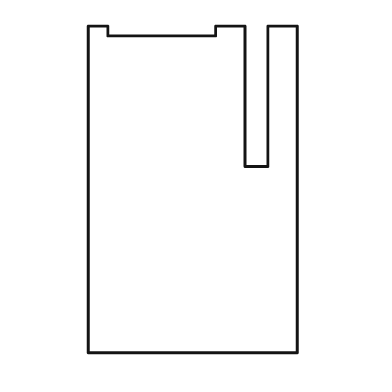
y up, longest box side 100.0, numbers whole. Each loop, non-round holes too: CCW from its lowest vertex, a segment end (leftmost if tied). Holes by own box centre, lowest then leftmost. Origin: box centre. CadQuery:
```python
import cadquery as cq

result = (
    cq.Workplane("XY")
    .moveTo(-32.0, -50.0)
    .lineTo(32.0, -50.0)
    .lineTo(32.0, 50.0)
    .lineTo(23.0, 50.0)
    .lineTo(23.0, 7.0)
    .lineTo(16.0, 7.0)
    .lineTo(16.0, 50.0)
    .lineTo(7.0, 50.0)
    .lineTo(7.0, 47.0)
    .lineTo(-26.0, 47.0)
    .lineTo(-26.0, 50.0)
    .lineTo(-32.0, 50.0)
    .close()
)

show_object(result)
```